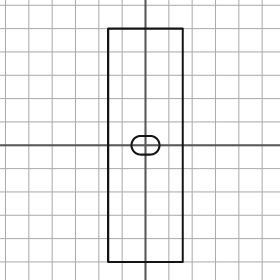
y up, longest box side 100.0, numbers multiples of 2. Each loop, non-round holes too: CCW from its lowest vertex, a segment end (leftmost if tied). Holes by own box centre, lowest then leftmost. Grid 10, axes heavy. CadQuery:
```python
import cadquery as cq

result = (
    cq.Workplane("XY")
    .moveTo(-16.0, -50.0)
    .lineTo(16.0, -50.0)
    .lineTo(16.0, 50.0)
    .lineTo(-16.0, 50.0)
    .close()
    .moveTo(-2.0, -4.0)
    .lineTo(2.0, -4.0)
    .threePointArc((6.0, 0.0), (2.0, 4.0))
    .lineTo(-2.0, 4.0)
    .threePointArc((-6.0, 0.0), (-2.0, -4.0))
    .close()
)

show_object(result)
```